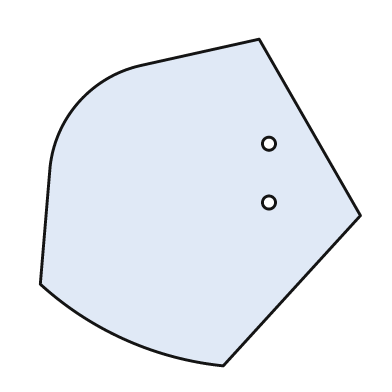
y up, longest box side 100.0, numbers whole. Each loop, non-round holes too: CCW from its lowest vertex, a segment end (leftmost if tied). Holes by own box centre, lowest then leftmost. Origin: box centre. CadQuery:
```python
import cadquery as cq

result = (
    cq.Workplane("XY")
    .moveTo(7.0, -50.0)
    .lineTo(49.0, -4.0)
    .lineTo(18.0, 50.0)
    .lineTo(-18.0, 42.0)
    .threePointArc((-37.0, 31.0), (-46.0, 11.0))
    .lineTo(-49.0, -25.0)
    .threePointArc((-23.0, -42.0), (7.0, -50.0))
    .close()
    .moveTo(21.0, 0.0)
    .circle(2.0)
    .moveTo(21.0, 18.0)
    .circle(2.0)
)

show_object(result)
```